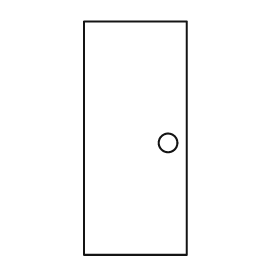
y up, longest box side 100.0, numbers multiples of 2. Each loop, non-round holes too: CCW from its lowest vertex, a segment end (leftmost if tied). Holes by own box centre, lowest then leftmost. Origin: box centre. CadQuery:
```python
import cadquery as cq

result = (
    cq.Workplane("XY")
    .moveTo(-22.0, -50.0)
    .lineTo(22.0, -50.0)
    .lineTo(22.0, 50.0)
    .lineTo(-22.0, 50.0)
    .close()
    .moveTo(14.0, -2.0)
    .circle(4.0)
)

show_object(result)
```